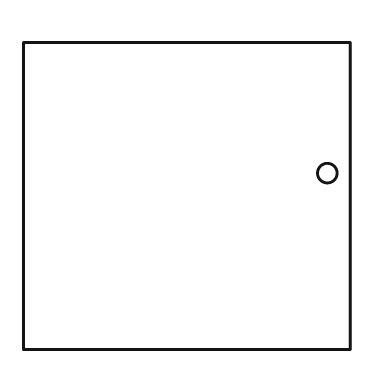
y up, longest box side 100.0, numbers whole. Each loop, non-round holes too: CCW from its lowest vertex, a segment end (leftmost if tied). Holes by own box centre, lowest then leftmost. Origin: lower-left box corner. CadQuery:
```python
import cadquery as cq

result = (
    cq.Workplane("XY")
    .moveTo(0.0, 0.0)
    .lineTo(100.0, 0.0)
    .lineTo(100.0, 94.0)
    .lineTo(0.0, 94.0)
    .close()
    .moveTo(93.0, 54.0)
    .circle(3.0)
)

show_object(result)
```